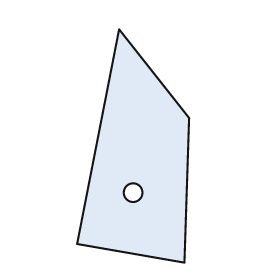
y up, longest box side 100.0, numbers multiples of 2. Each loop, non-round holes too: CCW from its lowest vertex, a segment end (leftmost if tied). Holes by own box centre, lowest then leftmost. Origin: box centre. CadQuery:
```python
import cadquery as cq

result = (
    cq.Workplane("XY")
    .moveTo(22.0, -50.0)
    .lineTo(24.0, 12.0)
    .lineTo(-6.0, 50.0)
    .lineTo(-24.0, -42.0)
    .close()
    .moveTo(0.0, -20.0)
    .circle(4.0)
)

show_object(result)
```